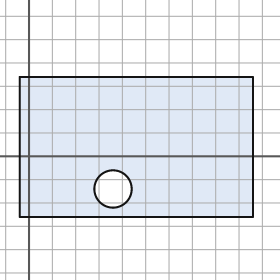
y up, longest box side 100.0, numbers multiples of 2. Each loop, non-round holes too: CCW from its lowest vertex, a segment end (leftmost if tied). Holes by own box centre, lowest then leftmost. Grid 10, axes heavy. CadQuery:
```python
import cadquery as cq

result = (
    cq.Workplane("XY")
    .moveTo(-4.0, -26.0)
    .lineTo(96.0, -26.0)
    .lineTo(96.0, 34.0)
    .lineTo(-4.0, 34.0)
    .close()
    .moveTo(36.0, -14.0)
    .circle(8.0)
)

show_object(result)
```